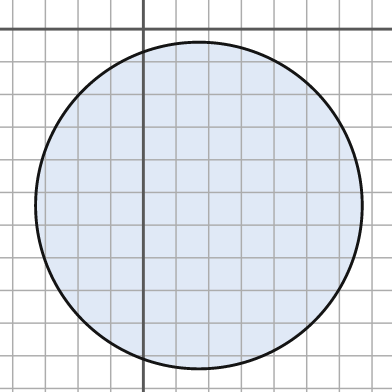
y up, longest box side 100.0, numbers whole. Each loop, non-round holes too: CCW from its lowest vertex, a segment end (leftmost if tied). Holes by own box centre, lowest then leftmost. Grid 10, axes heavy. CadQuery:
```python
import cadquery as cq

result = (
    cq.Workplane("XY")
    .moveTo(17.0, -54.0)
    .circle(50.0)
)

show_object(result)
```